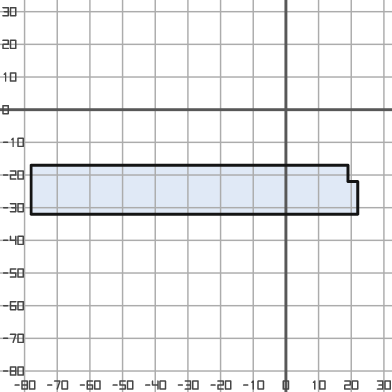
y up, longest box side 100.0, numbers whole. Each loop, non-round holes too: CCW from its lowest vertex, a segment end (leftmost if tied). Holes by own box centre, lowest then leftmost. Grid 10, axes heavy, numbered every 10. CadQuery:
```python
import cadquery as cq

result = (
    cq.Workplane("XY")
    .moveTo(-78.0, -32.0)
    .lineTo(22.0, -32.0)
    .lineTo(22.0, -22.0)
    .lineTo(19.0, -22.0)
    .lineTo(19.0, -17.0)
    .lineTo(-78.0, -17.0)
    .close()
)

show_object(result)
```